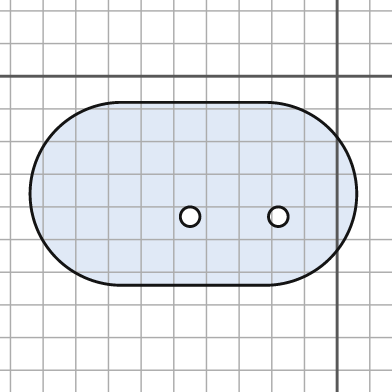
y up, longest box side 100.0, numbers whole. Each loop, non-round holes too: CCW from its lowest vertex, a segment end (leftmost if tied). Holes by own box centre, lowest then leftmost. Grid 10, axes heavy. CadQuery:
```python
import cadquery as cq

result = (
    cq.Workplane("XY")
    .moveTo(-66.0, -64.0)
    .lineTo(-22.0, -64.0)
    .threePointArc((6.0, -36.0), (-22.0, -8.0))
    .lineTo(-66.0, -8.0)
    .threePointArc((-94.0, -36.0), (-66.0, -64.0))
    .close()
    .moveTo(-45.0, -43.0)
    .circle(3.0)
    .moveTo(-18.0, -43.0)
    .circle(3.0)
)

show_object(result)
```